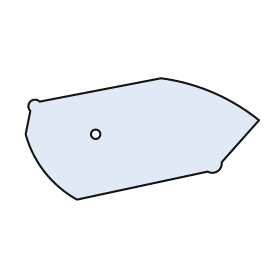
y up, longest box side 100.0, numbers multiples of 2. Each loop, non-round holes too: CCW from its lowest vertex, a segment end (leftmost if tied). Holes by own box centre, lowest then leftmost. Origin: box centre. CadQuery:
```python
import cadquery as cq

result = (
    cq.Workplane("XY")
    .moveTo(-28.0, -26.0)
    .lineTo(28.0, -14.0)
    .threePointArc((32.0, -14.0), (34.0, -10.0))
    .lineTo(50.0, 8.0)
    .threePointArc((30.0, 20.0), (8.0, 26.0))
    .lineTo(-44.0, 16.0)
    .threePointArc((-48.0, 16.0), (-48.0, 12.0))
    .lineTo(-50.0, 2.0)
    .threePointArc((-42.0, -14.0), (-28.0, -26.0))
    .close()
    .moveTo(-20.0, 2.0)
    .circle(2.0)
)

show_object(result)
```